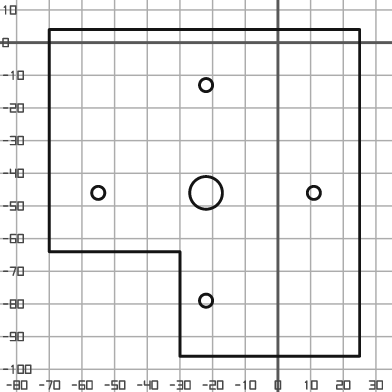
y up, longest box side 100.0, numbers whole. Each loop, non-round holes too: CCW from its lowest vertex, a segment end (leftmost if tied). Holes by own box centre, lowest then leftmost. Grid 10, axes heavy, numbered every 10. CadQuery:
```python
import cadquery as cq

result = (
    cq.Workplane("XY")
    .moveTo(-30.0, -96.0)
    .lineTo(25.0, -96.0)
    .lineTo(25.0, 4.0)
    .lineTo(-70.0, 4.0)
    .lineTo(-70.0, -64.0)
    .lineTo(-30.0, -64.0)
    .close()
    .moveTo(-22.0, -79.0)
    .circle(2.0)
    .moveTo(-55.0, -46.0)
    .circle(2.0)
    .moveTo(-22.0, -46.0)
    .circle(5.0)
    .moveTo(11.0, -46.0)
    .circle(2.0)
    .moveTo(-22.0, -13.0)
    .circle(2.0)
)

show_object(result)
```